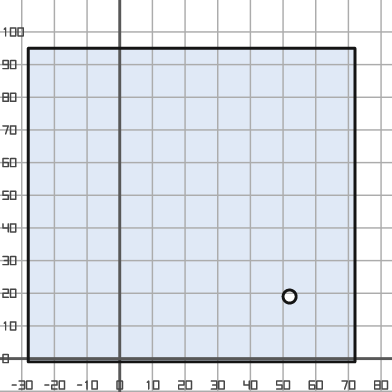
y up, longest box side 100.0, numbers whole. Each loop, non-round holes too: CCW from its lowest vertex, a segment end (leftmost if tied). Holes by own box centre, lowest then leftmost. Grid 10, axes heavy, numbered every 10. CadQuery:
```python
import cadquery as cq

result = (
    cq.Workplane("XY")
    .moveTo(-28.0, -1.0)
    .lineTo(72.0, -1.0)
    .lineTo(72.0, 95.0)
    .lineTo(-28.0, 95.0)
    .close()
    .moveTo(52.0, 19.0)
    .circle(2.0)
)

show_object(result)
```